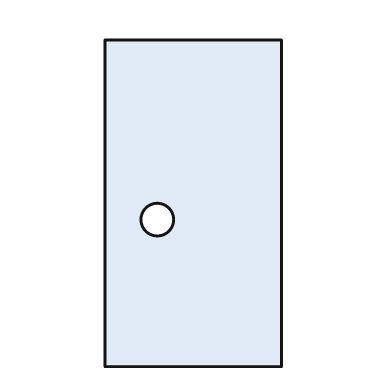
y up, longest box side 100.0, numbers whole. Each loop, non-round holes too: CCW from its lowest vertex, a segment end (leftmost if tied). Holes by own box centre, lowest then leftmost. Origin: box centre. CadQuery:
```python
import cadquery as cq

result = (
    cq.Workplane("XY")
    .moveTo(-27.0, -50.0)
    .lineTo(27.0, -50.0)
    .lineTo(27.0, 50.0)
    .lineTo(-27.0, 50.0)
    .close()
    .moveTo(-11.0, -5.0)
    .circle(5.0)
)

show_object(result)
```